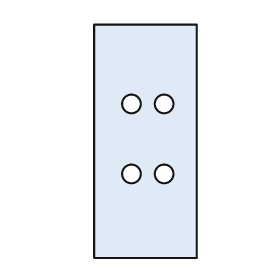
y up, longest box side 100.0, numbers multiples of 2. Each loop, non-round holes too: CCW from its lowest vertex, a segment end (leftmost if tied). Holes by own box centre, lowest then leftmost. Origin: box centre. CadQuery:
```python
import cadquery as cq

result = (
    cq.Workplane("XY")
    .moveTo(-22.0, -50.0)
    .lineTo(22.0, -50.0)
    .lineTo(22.0, 50.0)
    .lineTo(-22.0, 50.0)
    .close()
    .moveTo(-6.0, -14.0)
    .circle(4.0)
    .moveTo(8.0, -14.0)
    .circle(4.0)
    .moveTo(-6.0, 16.0)
    .circle(4.0)
    .moveTo(8.0, 16.0)
    .circle(4.0)
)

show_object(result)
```